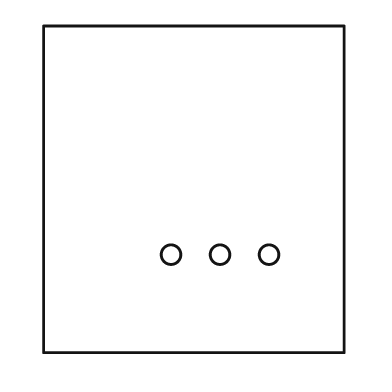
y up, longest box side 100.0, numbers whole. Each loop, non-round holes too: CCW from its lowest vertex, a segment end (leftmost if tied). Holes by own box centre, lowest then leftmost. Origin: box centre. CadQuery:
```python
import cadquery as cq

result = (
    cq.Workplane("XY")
    .moveTo(-46.0, -50.0)
    .lineTo(46.0, -50.0)
    .lineTo(46.0, 50.0)
    .lineTo(-46.0, 50.0)
    .close()
    .moveTo(-7.0, -20.0)
    .circle(3.0)
    .moveTo(8.0, -20.0)
    .circle(3.0)
    .moveTo(23.0, -20.0)
    .circle(3.0)
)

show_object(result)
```